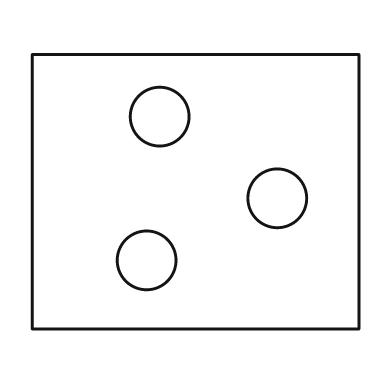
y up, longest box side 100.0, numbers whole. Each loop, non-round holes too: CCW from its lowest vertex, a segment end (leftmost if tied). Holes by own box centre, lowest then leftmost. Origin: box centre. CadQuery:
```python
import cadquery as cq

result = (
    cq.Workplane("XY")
    .moveTo(-50.0, -42.0)
    .lineTo(50.0, -42.0)
    .lineTo(50.0, 42.0)
    .lineTo(-50.0, 42.0)
    .close()
    .moveTo(-15.0, -21.0)
    .circle(9.0)
    .moveTo(25.0, -2.0)
    .circle(9.0)
    .moveTo(-11.0, 23.0)
    .circle(9.0)
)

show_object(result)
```